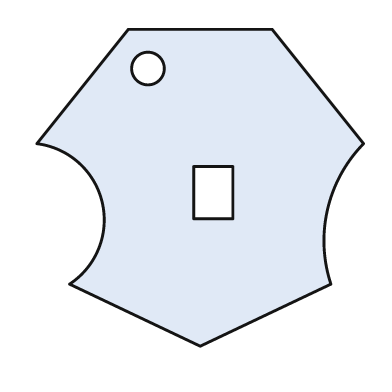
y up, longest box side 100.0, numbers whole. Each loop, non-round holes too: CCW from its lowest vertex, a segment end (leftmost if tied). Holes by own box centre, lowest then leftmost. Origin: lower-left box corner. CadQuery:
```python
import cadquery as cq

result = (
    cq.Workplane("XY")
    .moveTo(50.0, 0.0)
    .lineTo(90.0, 19.0)
    .threePointArc((89.0, 42.0), (100.0, 62.0))
    .lineTo(72.0, 97.0)
    .lineTo(28.0, 97.0)
    .lineTo(0.0, 62.0)
    .threePointArc((20.0, 44.0), (10.0, 19.0))
    .close()
    .moveTo(48.0, 39.0)
    .lineTo(60.0, 39.0)
    .lineTo(60.0, 55.0)
    .lineTo(48.0, 55.0)
    .close()
    .moveTo(34.0, 85.0)
    .circle(5.0)
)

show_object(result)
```